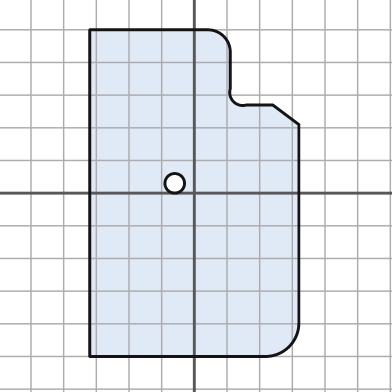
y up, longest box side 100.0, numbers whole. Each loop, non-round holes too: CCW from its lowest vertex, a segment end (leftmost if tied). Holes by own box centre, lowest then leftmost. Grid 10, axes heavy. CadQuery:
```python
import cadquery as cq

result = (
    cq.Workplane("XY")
    .moveTo(-32.0, -50.0)
    .lineTo(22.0, -50.0)
    .threePointArc((29.0, -47.0), (32.0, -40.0))
    .lineTo(32.0, 21.0)
    .lineTo(24.0, 27.0)
    .lineTo(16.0, 27.0)
    .threePointArc((12.0, 28.0), (11.0, 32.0))
    .lineTo(11.0, 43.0)
    .threePointArc((9.0, 48.0), (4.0, 50.0))
    .lineTo(-32.0, 50.0)
    .close()
    .moveTo(-6.0, 3.0)
    .circle(3.0)
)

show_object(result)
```